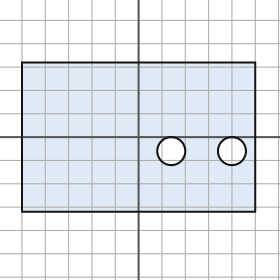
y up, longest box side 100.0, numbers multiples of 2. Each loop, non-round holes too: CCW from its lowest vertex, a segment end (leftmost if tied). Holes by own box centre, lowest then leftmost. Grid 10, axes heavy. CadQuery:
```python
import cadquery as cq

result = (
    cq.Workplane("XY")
    .moveTo(-50.0, -32.0)
    .lineTo(50.0, -32.0)
    .lineTo(50.0, 32.0)
    .lineTo(-50.0, 32.0)
    .close()
    .moveTo(14.0, -6.0)
    .circle(6.0)
    .moveTo(40.0, -6.0)
    .circle(6.0)
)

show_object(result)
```